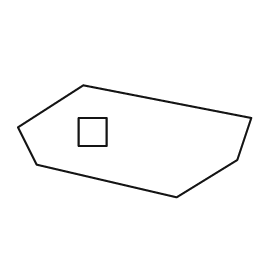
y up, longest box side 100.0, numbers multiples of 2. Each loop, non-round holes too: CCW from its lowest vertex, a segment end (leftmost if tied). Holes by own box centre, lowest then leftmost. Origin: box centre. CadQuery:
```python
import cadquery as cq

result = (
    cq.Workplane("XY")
    .moveTo(18.0, -24.0)
    .lineTo(44.0, -8.0)
    .lineTo(50.0, 10.0)
    .lineTo(-22.0, 24.0)
    .lineTo(-50.0, 6.0)
    .lineTo(-42.0, -10.0)
    .close()
    .moveTo(-24.0, -2.0)
    .lineTo(-12.0, -2.0)
    .lineTo(-12.0, 10.0)
    .lineTo(-24.0, 10.0)
    .close()
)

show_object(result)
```